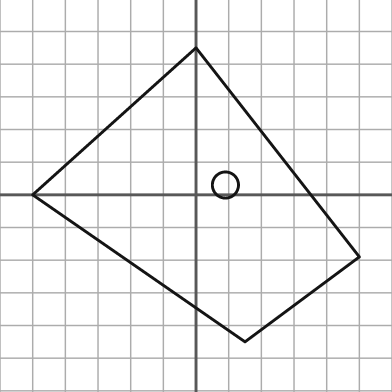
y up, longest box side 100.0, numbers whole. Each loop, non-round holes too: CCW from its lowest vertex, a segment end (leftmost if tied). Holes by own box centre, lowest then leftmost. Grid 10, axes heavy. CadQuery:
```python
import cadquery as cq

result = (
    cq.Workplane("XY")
    .moveTo(15.0, -45.0)
    .lineTo(50.0, -19.0)
    .lineTo(0.0, 45.0)
    .lineTo(-50.0, 0.0)
    .close()
    .moveTo(9.0, 3.0)
    .circle(4.0)
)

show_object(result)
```